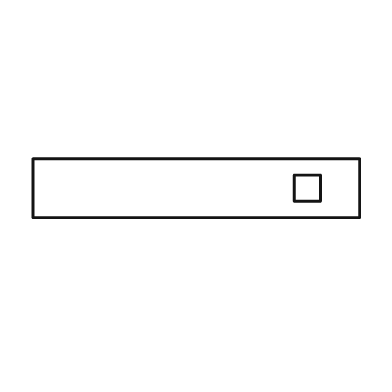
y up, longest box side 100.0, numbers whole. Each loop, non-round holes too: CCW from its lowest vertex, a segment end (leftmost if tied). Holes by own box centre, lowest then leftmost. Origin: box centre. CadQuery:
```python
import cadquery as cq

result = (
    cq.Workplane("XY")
    .moveTo(-50.0, -9.0)
    .lineTo(50.0, -9.0)
    .lineTo(50.0, 9.0)
    .lineTo(-50.0, 9.0)
    .close()
    .moveTo(30.0, -4.0)
    .lineTo(38.0, -4.0)
    .lineTo(38.0, 4.0)
    .lineTo(30.0, 4.0)
    .close()
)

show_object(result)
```